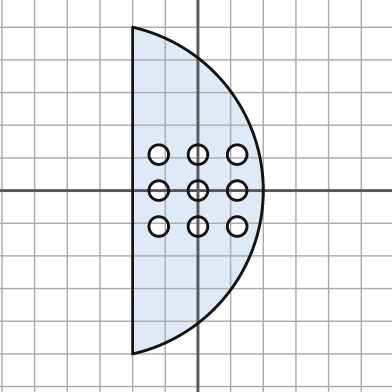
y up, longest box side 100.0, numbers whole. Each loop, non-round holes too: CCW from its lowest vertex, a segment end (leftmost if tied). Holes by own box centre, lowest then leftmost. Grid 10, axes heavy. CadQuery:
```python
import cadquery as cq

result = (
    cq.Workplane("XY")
    .moveTo(-20.0, -50.0)
    .threePointArc((20.0, 0.0), (-20.0, 50.0))
    .close()
    .moveTo(-12.0, -11.0)
    .circle(3.0)
    .moveTo(0.0, -11.0)
    .circle(3.0)
    .moveTo(12.0, -11.0)
    .circle(3.0)
    .moveTo(-12.0, 0.0)
    .circle(3.0)
    .moveTo(0.0, 0.0)
    .circle(3.0)
    .moveTo(12.0, 0.0)
    .circle(3.0)
    .moveTo(-12.0, 11.0)
    .circle(3.0)
    .moveTo(0.0, 11.0)
    .circle(3.0)
    .moveTo(12.0, 11.0)
    .circle(3.0)
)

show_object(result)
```